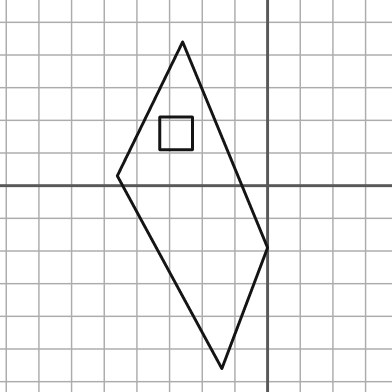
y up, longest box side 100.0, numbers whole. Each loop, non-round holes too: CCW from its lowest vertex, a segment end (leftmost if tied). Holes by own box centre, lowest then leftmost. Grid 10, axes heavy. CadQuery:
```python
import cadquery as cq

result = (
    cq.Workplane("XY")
    .moveTo(-14.0, -56.0)
    .lineTo(0.0, -19.0)
    .lineTo(-26.0, 44.0)
    .lineTo(-46.0, 3.0)
    .close()
    .moveTo(-33.0, 11.0)
    .lineTo(-23.0, 11.0)
    .lineTo(-23.0, 21.0)
    .lineTo(-33.0, 21.0)
    .close()
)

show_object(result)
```